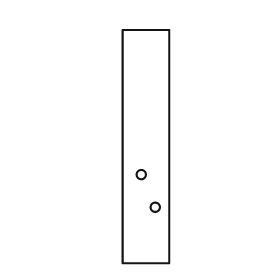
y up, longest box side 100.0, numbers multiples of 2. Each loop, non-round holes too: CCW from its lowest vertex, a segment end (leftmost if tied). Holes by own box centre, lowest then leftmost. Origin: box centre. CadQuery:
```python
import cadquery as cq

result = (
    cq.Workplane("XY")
    .moveTo(-10.0, -50.0)
    .lineTo(10.0, -50.0)
    .lineTo(10.0, 50.0)
    .lineTo(-10.0, 50.0)
    .close()
    .moveTo(4.0, -26.0)
    .circle(2.0)
    .moveTo(-2.0, -12.0)
    .circle(2.0)
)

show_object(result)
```